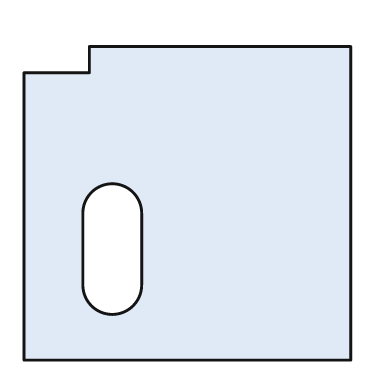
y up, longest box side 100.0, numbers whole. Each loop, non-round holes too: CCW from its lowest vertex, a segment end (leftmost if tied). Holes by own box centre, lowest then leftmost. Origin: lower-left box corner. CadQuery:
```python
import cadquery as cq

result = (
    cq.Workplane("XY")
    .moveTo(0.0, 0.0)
    .lineTo(100.0, 0.0)
    .lineTo(100.0, 96.0)
    .lineTo(20.0, 96.0)
    .lineTo(20.0, 88.0)
    .lineTo(0.0, 88.0)
    .close()
    .moveTo(18.0, 23.0)
    .threePointArc((27.0, 14.0), (36.0, 23.0))
    .lineTo(36.0, 45.0)
    .threePointArc((27.0, 54.0), (18.0, 45.0))
    .close()
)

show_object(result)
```